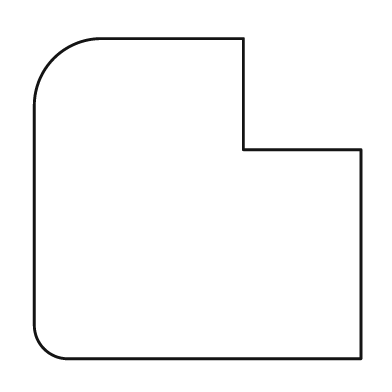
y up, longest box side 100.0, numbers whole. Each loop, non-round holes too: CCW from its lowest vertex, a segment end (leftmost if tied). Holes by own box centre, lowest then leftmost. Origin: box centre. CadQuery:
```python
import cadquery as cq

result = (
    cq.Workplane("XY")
    .moveTo(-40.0, -49.0)
    .lineTo(50.0, -49.0)
    .lineTo(50.0, 15.0)
    .lineTo(14.0, 15.0)
    .lineTo(14.0, 49.0)
    .lineTo(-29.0, 49.0)
    .threePointArc((-44.0, 43.0), (-50.0, 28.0))
    .lineTo(-50.0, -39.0)
    .threePointArc((-47.0, -46.0), (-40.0, -49.0))
    .close()
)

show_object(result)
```